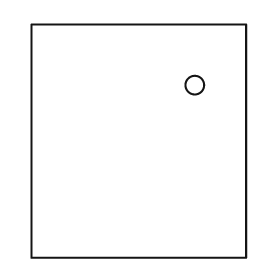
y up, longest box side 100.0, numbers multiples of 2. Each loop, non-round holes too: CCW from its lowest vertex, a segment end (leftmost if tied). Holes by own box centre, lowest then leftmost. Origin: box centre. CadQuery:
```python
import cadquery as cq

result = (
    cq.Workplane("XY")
    .moveTo(-46.0, -50.0)
    .lineTo(46.0, -50.0)
    .lineTo(46.0, 50.0)
    .lineTo(-46.0, 50.0)
    .close()
    .moveTo(24.0, 24.0)
    .circle(4.0)
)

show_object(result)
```